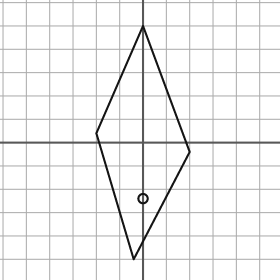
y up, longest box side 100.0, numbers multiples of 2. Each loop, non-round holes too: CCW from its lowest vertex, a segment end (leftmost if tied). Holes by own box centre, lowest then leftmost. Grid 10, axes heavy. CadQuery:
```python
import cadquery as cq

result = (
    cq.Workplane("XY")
    .moveTo(-4.0, -50.0)
    .lineTo(20.0, -4.0)
    .lineTo(0.0, 50.0)
    .lineTo(-20.0, 4.0)
    .close()
    .moveTo(0.0, -24.0)
    .circle(2.0)
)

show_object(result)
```